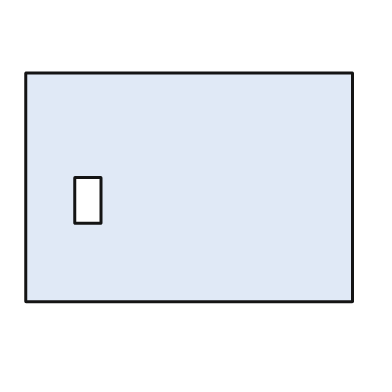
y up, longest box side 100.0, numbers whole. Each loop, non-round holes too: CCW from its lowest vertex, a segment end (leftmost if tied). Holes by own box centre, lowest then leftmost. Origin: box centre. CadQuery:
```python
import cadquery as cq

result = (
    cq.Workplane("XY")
    .moveTo(-50.0, -35.0)
    .lineTo(50.0, -35.0)
    .lineTo(50.0, 35.0)
    .lineTo(-50.0, 35.0)
    .close()
    .moveTo(-35.0, -11.0)
    .lineTo(-27.0, -11.0)
    .lineTo(-27.0, 3.0)
    .lineTo(-35.0, 3.0)
    .close()
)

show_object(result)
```